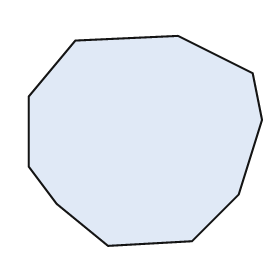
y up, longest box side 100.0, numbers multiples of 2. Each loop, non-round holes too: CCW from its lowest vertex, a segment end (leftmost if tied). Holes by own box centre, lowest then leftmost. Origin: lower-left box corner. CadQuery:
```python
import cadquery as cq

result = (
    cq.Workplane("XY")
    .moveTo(34.0, 0.0)
    .lineTo(70.0, 2.0)
    .lineTo(90.0, 22.0)
    .lineTo(100.0, 54.0)
    .lineTo(96.0, 74.0)
    .lineTo(64.0, 90.0)
    .lineTo(20.0, 88.0)
    .lineTo(0.0, 64.0)
    .lineTo(0.0, 34.0)
    .lineTo(12.0, 18.0)
    .close()
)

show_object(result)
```